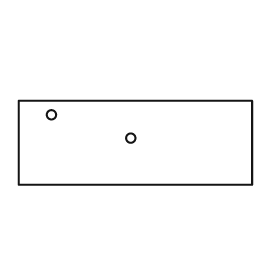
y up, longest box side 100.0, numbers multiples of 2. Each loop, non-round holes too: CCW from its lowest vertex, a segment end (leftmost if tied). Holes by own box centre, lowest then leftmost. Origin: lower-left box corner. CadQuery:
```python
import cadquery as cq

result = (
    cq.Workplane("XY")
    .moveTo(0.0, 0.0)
    .lineTo(100.0, 0.0)
    .lineTo(100.0, 36.0)
    .lineTo(0.0, 36.0)
    .close()
    .moveTo(48.0, 20.0)
    .circle(2.0)
    .moveTo(14.0, 30.0)
    .circle(2.0)
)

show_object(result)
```